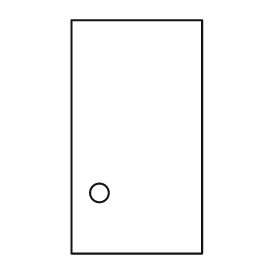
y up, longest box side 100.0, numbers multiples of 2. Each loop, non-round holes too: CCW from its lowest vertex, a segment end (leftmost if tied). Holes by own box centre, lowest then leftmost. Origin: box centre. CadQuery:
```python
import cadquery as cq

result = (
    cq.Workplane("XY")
    .moveTo(-28.0, -50.0)
    .lineTo(28.0, -50.0)
    .lineTo(28.0, 50.0)
    .lineTo(-28.0, 50.0)
    .close()
    .moveTo(-16.0, -24.0)
    .circle(4.0)
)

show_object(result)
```